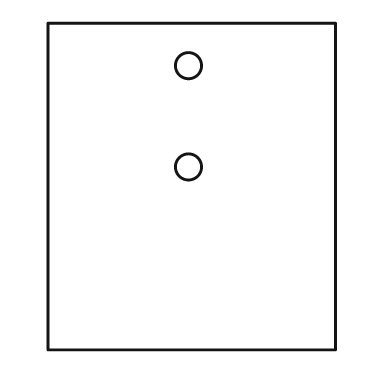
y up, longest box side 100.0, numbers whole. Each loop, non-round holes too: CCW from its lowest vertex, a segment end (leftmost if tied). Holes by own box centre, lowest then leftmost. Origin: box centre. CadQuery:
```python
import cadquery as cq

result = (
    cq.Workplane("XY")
    .moveTo(-44.0, -50.0)
    .lineTo(44.0, -50.0)
    .lineTo(44.0, 50.0)
    .lineTo(-44.0, 50.0)
    .close()
    .moveTo(-1.0, 6.0)
    .circle(4.0)
    .moveTo(-1.0, 37.0)
    .circle(4.0)
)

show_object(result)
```